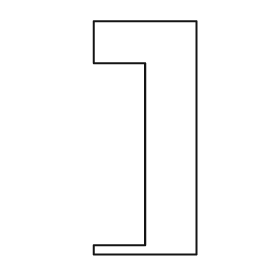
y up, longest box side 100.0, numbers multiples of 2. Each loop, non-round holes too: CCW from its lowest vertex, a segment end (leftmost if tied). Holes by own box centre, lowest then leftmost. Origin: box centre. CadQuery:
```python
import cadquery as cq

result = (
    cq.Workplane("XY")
    .moveTo(-22.0, -50.0)
    .lineTo(22.0, -50.0)
    .lineTo(22.0, 50.0)
    .lineTo(-22.0, 50.0)
    .lineTo(-22.0, 32.0)
    .lineTo(0.0, 32.0)
    .lineTo(0.0, -46.0)
    .lineTo(-22.0, -46.0)
    .close()
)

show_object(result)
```